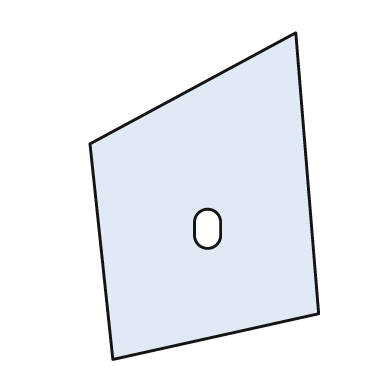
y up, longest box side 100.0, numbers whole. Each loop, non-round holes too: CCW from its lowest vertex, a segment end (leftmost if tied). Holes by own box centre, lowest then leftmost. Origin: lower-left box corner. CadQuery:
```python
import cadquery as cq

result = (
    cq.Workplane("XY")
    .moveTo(7.0, 0.0)
    .lineTo(70.0, 14.0)
    .lineTo(63.0, 100.0)
    .lineTo(0.0, 66.0)
    .close()
    .moveTo(32.0, 38.0)
    .threePointArc((36.0, 34.0), (40.0, 38.0))
    .lineTo(40.0, 42.0)
    .threePointArc((36.0, 46.0), (32.0, 42.0))
    .close()
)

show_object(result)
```